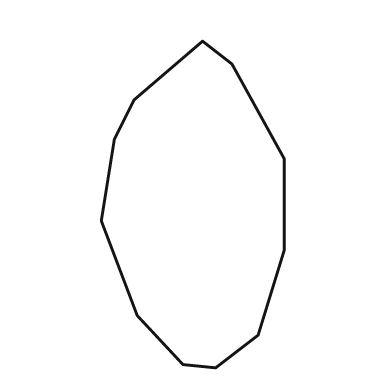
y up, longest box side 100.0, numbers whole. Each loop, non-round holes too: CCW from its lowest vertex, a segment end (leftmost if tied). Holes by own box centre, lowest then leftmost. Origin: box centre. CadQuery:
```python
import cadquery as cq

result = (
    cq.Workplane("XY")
    .moveTo(7.0, -50.0)
    .lineTo(20.0, -40.0)
    .lineTo(28.0, -14.0)
    .lineTo(28.0, 14.0)
    .lineTo(12.0, 43.0)
    .lineTo(3.0, 50.0)
    .lineTo(-18.0, 32.0)
    .lineTo(-24.0, 20.0)
    .lineTo(-28.0, -5.0)
    .lineTo(-17.0, -34.0)
    .lineTo(-3.0, -49.0)
    .close()
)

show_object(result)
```